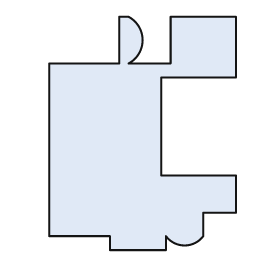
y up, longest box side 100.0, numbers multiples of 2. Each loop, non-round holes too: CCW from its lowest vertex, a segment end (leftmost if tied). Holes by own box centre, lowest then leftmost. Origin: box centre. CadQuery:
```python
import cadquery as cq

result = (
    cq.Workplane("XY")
    .moveTo(-14.0, -50.0)
    .lineTo(10.0, -50.0)
    .lineTo(10.0, -44.0)
    .threePointArc((18.0, -48.0), (26.0, -44.0))
    .lineTo(26.0, -34.0)
    .lineTo(40.0, -34.0)
    .lineTo(40.0, -18.0)
    .lineTo(8.0, -18.0)
    .lineTo(8.0, 24.0)
    .lineTo(40.0, 24.0)
    .lineTo(40.0, 50.0)
    .lineTo(12.0, 50.0)
    .lineTo(12.0, 30.0)
    .lineTo(-6.0, 30.0)
    .threePointArc((0.0, 40.0), (-6.0, 50.0))
    .lineTo(-10.0, 50.0)
    .lineTo(-10.0, 30.0)
    .lineTo(-40.0, 30.0)
    .lineTo(-40.0, -44.0)
    .lineTo(-14.0, -44.0)
    .close()
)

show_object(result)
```